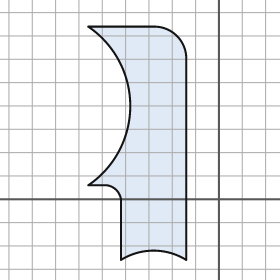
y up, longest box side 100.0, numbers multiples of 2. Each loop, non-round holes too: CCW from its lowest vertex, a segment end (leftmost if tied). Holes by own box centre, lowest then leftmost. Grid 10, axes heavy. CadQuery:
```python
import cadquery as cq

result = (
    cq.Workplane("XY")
    .moveTo(-42.0, -26.0)
    .threePointArc((-28.0, -22.0), (-14.0, -26.0))
    .lineTo(-14.0, 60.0)
    .threePointArc((-18.0, 70.0), (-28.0, 74.0))
    .lineTo(-56.0, 74.0)
    .threePointArc((-38.0, 40.0), (-56.0, 6.0))
    .lineTo(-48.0, 6.0)
    .threePointArc((-44.0, 4.0), (-42.0, 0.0))
    .close()
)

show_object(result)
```